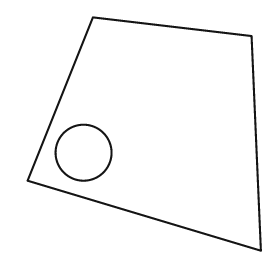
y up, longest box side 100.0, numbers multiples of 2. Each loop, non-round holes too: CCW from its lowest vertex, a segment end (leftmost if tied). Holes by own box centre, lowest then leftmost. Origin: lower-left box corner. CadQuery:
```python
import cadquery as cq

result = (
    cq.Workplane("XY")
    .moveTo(100.0, 0.0)
    .lineTo(96.0, 92.0)
    .lineTo(28.0, 100.0)
    .lineTo(0.0, 30.0)
    .close()
    .moveTo(24.0, 42.0)
    .circle(12.0)
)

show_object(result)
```